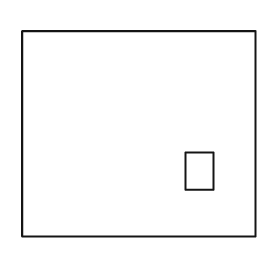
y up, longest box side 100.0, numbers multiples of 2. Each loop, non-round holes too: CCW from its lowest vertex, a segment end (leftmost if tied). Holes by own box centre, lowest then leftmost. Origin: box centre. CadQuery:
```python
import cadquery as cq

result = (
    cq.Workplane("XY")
    .moveTo(-50.0, -44.0)
    .lineTo(50.0, -44.0)
    .lineTo(50.0, 44.0)
    .lineTo(-50.0, 44.0)
    .close()
    .moveTo(20.0, -24.0)
    .lineTo(32.0, -24.0)
    .lineTo(32.0, -8.0)
    .lineTo(20.0, -8.0)
    .close()
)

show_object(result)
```